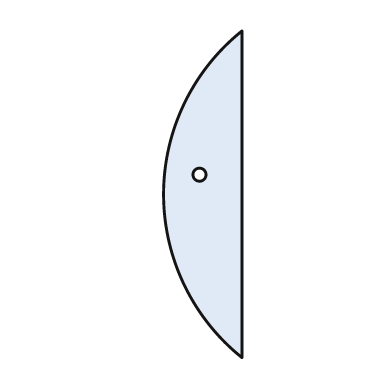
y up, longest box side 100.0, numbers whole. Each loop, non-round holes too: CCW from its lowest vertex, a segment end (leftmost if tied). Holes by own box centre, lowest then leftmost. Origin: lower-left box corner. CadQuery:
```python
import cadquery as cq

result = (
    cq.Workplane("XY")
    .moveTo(24.0, 0.0)
    .lineTo(24.0, 100.0)
    .threePointArc((0.0, 50.0), (24.0, 0.0))
    .close()
    .moveTo(11.0, 56.0)
    .circle(2.0)
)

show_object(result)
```